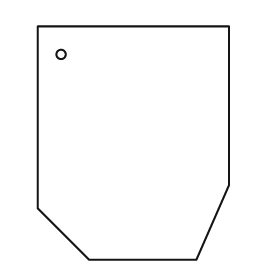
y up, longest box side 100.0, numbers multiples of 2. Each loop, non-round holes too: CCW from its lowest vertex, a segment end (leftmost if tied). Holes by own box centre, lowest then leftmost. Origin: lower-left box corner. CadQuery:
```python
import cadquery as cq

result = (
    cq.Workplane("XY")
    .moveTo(22.0, 0.0)
    .lineTo(68.0, 0.0)
    .lineTo(82.0, 32.0)
    .lineTo(82.0, 100.0)
    .lineTo(0.0, 100.0)
    .lineTo(0.0, 22.0)
    .close()
    .moveTo(10.0, 88.0)
    .circle(2.0)
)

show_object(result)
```